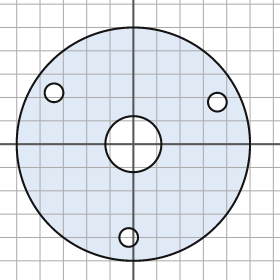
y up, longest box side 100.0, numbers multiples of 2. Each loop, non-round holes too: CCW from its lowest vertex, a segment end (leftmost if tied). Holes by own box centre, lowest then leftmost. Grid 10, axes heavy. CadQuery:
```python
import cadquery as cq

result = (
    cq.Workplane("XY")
    .moveTo(0.0, 0.0)
    .circle(50.0)
    .moveTo(-2.0, -40.0)
    .circle(4.0)
    .moveTo(0.0, 0.0)
    .circle(12.0)
    .moveTo(36.0, 18.0)
    .circle(4.0)
    .moveTo(-34.0, 22.0)
    .circle(4.0)
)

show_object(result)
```